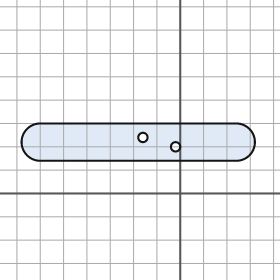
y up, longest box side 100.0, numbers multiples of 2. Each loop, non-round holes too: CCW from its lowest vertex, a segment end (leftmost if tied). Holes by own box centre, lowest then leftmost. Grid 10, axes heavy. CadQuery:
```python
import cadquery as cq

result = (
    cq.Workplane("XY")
    .moveTo(-60.0, 14.0)
    .lineTo(24.0, 14.0)
    .threePointArc((32.0, 22.0), (24.0, 30.0))
    .lineTo(-60.0, 30.0)
    .threePointArc((-68.0, 22.0), (-60.0, 14.0))
    .close()
    .moveTo(-2.0, 20.0)
    .circle(2.0)
    .moveTo(-16.0, 24.0)
    .circle(2.0)
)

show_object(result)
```